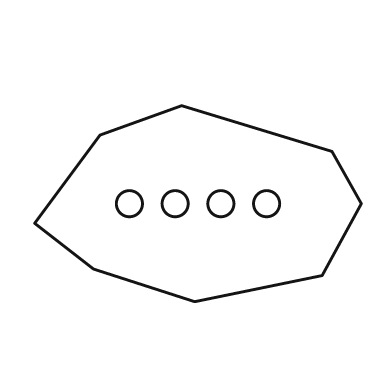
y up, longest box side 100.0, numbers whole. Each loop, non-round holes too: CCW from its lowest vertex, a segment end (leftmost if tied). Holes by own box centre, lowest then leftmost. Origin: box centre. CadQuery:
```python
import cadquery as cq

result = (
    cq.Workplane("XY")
    .moveTo(-1.0, -30.0)
    .lineTo(38.0, -22.0)
    .lineTo(50.0, 0.0)
    .lineTo(41.0, 16.0)
    .lineTo(-5.0, 30.0)
    .lineTo(-30.0, 21.0)
    .lineTo(-50.0, -6.0)
    .lineTo(-32.0, -20.0)
    .close()
    .moveTo(-21.0, 0.0)
    .circle(4.0)
    .moveTo(-7.0, 0.0)
    .circle(4.0)
    .moveTo(7.0, 0.0)
    .circle(4.0)
    .moveTo(21.0, 0.0)
    .circle(4.0)
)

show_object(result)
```